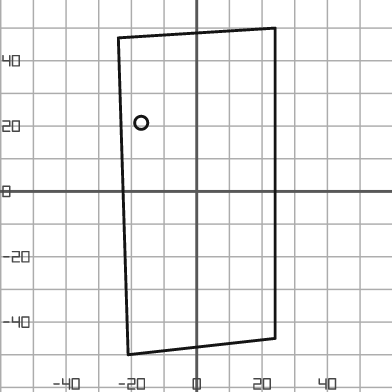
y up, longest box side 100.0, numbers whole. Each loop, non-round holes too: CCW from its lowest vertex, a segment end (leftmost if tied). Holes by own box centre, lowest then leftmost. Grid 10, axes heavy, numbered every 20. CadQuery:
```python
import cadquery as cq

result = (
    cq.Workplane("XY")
    .moveTo(-21.0, -50.0)
    .lineTo(24.0, -45.0)
    .lineTo(24.0, 50.0)
    .lineTo(-24.0, 47.0)
    .close()
    .moveTo(-17.0, 21.0)
    .circle(2.0)
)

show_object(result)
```